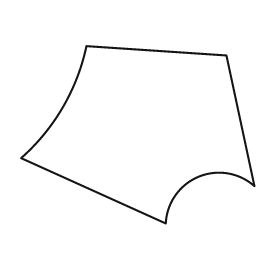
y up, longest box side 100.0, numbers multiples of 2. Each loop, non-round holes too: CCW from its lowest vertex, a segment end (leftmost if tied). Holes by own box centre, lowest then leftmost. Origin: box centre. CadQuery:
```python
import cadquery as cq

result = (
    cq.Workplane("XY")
    .moveTo(12.0, -38.0)
    .threePointArc((26.0, -18.0), (50.0, -22.0))
    .lineTo(38.0, 34.0)
    .lineTo(-22.0, 38.0)
    .threePointArc((-32.0, 12.0), (-50.0, -10.0))
    .close()
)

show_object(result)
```